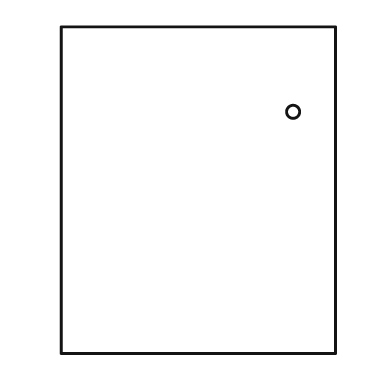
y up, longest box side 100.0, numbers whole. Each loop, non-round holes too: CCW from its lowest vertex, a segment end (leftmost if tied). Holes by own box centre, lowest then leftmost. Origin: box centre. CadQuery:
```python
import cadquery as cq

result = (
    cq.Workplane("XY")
    .moveTo(-42.0, -50.0)
    .lineTo(42.0, -50.0)
    .lineTo(42.0, 50.0)
    .lineTo(-42.0, 50.0)
    .close()
    .moveTo(29.0, 24.0)
    .circle(2.0)
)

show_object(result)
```